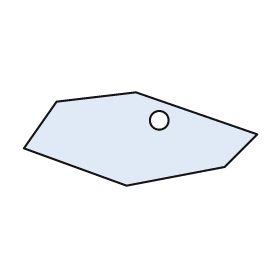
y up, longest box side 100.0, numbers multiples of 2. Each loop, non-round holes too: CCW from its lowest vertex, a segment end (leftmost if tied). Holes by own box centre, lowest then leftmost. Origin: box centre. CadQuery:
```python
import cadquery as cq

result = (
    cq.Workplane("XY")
    .moveTo(-6.0, -20.0)
    .lineTo(36.0, -12.0)
    .lineTo(50.0, 2.0)
    .lineTo(-2.0, 20.0)
    .lineTo(-36.0, 16.0)
    .lineTo(-50.0, -4.0)
    .close()
    .moveTo(8.0, 8.0)
    .circle(4.0)
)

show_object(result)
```